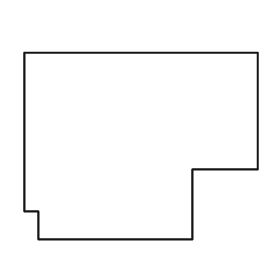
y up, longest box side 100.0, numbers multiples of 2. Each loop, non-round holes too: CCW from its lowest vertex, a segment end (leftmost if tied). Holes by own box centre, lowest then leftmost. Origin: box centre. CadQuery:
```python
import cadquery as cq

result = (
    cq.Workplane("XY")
    .moveTo(-44.0, -40.0)
    .lineTo(22.0, -40.0)
    .lineTo(22.0, -10.0)
    .lineTo(50.0, -10.0)
    .lineTo(50.0, 40.0)
    .lineTo(-50.0, 40.0)
    .lineTo(-50.0, -28.0)
    .lineTo(-44.0, -28.0)
    .close()
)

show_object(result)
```